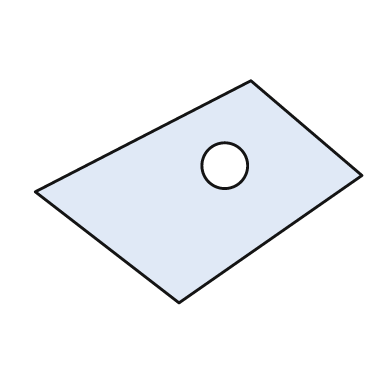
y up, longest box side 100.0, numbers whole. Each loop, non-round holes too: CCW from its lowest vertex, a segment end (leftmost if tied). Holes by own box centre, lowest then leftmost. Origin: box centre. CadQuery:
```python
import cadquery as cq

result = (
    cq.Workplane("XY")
    .moveTo(-6.0, -34.0)
    .lineTo(50.0, 5.0)
    .lineTo(16.0, 34.0)
    .lineTo(-50.0, 0.0)
    .close()
    .moveTo(8.0, 8.0)
    .circle(7.0)
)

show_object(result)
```